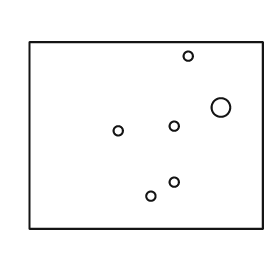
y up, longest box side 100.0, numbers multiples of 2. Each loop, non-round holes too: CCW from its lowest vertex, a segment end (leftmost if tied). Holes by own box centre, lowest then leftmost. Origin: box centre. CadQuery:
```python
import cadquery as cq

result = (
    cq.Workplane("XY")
    .moveTo(-50.0, -40.0)
    .lineTo(50.0, -40.0)
    .lineTo(50.0, 40.0)
    .lineTo(-50.0, 40.0)
    .close()
    .moveTo(2.0, -26.0)
    .circle(2.0)
    .moveTo(12.0, -20.0)
    .circle(2.0)
    .moveTo(-12.0, 2.0)
    .circle(2.0)
    .moveTo(12.0, 4.0)
    .circle(2.0)
    .moveTo(32.0, 12.0)
    .circle(4.0)
    .moveTo(18.0, 34.0)
    .circle(2.0)
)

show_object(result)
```